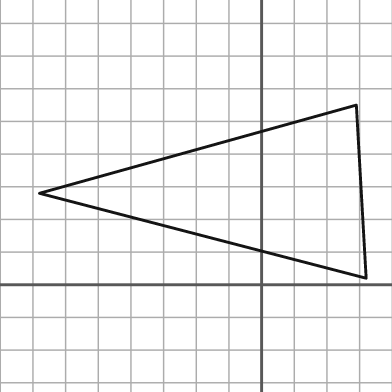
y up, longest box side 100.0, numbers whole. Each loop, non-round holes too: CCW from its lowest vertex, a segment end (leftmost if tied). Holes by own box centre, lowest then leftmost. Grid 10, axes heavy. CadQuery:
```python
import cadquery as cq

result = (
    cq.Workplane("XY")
    .moveTo(32.0, 2.0)
    .lineTo(29.0, 55.0)
    .lineTo(-68.0, 28.0)
    .close()
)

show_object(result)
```